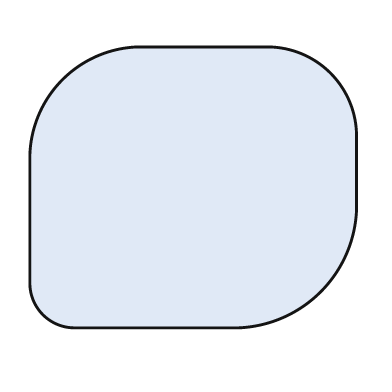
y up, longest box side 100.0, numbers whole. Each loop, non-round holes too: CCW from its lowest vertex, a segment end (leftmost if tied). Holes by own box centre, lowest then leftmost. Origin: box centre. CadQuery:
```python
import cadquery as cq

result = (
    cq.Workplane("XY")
    .moveTo(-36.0, -43.0)
    .lineTo(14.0, -43.0)
    .threePointArc((39.0, -32.0), (50.0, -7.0))
    .lineTo(50.0, 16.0)
    .threePointArc((42.0, 35.0), (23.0, 43.0))
    .lineTo(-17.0, 43.0)
    .threePointArc((-40.0, 33.0), (-50.0, 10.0))
    .lineTo(-50.0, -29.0)
    .threePointArc((-46.0, -39.0), (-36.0, -43.0))
    .close()
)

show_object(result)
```